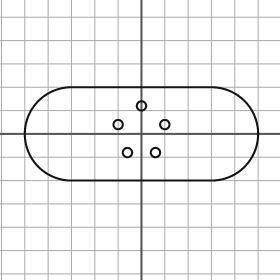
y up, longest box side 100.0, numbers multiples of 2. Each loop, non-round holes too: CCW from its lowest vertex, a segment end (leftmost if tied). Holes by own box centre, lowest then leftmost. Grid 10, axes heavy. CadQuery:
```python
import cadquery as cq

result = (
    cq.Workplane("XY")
    .moveTo(-30.0, -20.0)
    .lineTo(30.0, -20.0)
    .threePointArc((50.0, 0.0), (30.0, 20.0))
    .lineTo(-30.0, 20.0)
    .threePointArc((-50.0, 0.0), (-30.0, -20.0))
    .close()
    .moveTo(-6.0, -8.0)
    .circle(2.0)
    .moveTo(6.0, -8.0)
    .circle(2.0)
    .moveTo(-10.0, 4.0)
    .circle(2.0)
    .moveTo(10.0, 4.0)
    .circle(2.0)
    .moveTo(0.0, 12.0)
    .circle(2.0)
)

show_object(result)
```